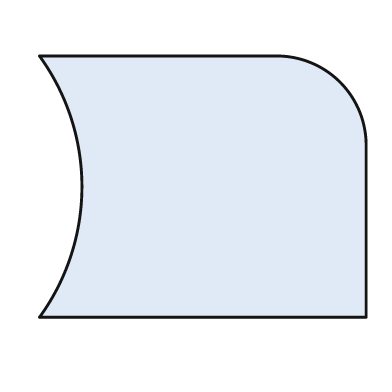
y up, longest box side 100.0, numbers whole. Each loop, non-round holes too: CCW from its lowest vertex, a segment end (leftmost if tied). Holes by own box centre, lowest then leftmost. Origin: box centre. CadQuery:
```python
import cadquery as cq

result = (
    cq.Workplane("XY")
    .moveTo(-50.0, -40.0)
    .lineTo(50.0, -40.0)
    .lineTo(50.0, 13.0)
    .threePointArc((42.0, 32.0), (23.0, 40.0))
    .lineTo(-50.0, 40.0)
    .threePointArc((-37.0, 0.0), (-50.0, -40.0))
    .close()
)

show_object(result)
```